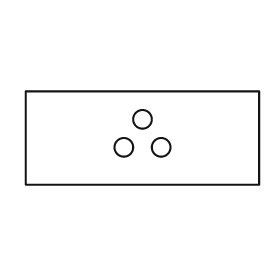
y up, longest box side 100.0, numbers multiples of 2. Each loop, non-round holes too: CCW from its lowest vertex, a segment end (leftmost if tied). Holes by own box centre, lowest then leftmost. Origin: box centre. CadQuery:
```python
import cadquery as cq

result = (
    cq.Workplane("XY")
    .moveTo(-50.0, -20.0)
    .lineTo(50.0, -20.0)
    .lineTo(50.0, 20.0)
    .lineTo(-50.0, 20.0)
    .close()
    .moveTo(-8.0, -4.0)
    .circle(4.0)
    .moveTo(8.0, -4.0)
    .circle(4.0)
    .moveTo(0.0, 8.0)
    .circle(4.0)
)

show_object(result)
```